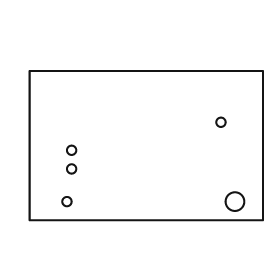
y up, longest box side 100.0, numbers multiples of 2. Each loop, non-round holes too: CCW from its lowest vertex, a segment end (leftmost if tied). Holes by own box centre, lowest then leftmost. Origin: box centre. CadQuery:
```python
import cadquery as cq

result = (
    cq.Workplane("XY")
    .moveTo(-50.0, -32.0)
    .lineTo(50.0, -32.0)
    .lineTo(50.0, 32.0)
    .lineTo(-50.0, 32.0)
    .close()
    .moveTo(-34.0, -24.0)
    .circle(2.0)
    .moveTo(38.0, -24.0)
    .circle(4.0)
    .moveTo(-32.0, -10.0)
    .circle(2.0)
    .moveTo(-32.0, -2.0)
    .circle(2.0)
    .moveTo(32.0, 10.0)
    .circle(2.0)
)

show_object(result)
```